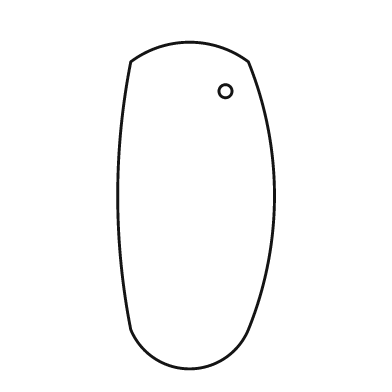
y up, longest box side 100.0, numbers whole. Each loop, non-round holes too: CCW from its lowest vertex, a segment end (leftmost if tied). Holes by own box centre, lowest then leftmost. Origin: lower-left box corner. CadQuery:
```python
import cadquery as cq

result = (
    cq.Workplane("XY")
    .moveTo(4.0, 12.0)
    .threePointArc((22.0, 0.0), (40.0, 12.0))
    .threePointArc((48.0, 53.0), (40.0, 94.0))
    .threePointArc((22.0, 100.0), (4.0, 94.0))
    .threePointArc((0.0, 53.0), (4.0, 12.0))
    .close()
    .moveTo(33.0, 85.0)
    .circle(2.0)
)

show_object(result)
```